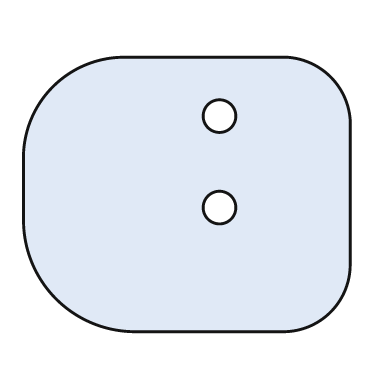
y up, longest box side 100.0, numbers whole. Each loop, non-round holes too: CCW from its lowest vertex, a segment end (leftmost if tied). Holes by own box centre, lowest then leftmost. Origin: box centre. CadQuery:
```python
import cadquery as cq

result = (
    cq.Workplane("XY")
    .moveTo(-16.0, -42.0)
    .lineTo(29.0, -42.0)
    .threePointArc((44.0, -36.0), (50.0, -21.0))
    .lineTo(50.0, 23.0)
    .threePointArc((44.0, 36.0), (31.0, 42.0))
    .lineTo(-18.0, 42.0)
    .threePointArc((-41.0, 33.0), (-50.0, 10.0))
    .lineTo(-50.0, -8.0)
    .threePointArc((-40.0, -32.0), (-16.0, -42.0))
    .close()
    .moveTo(10.0, -4.0)
    .circle(5.0)
    .moveTo(10.0, 24.0)
    .circle(5.0)
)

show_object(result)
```